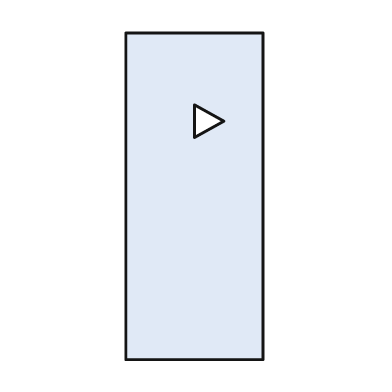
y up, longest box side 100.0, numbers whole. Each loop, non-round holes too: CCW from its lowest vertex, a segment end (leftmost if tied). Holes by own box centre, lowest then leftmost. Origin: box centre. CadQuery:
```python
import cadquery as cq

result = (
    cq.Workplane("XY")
    .moveTo(-21.0, -50.0)
    .lineTo(21.0, -50.0)
    .lineTo(21.0, 50.0)
    .lineTo(-21.0, 50.0)
    .close()
    .moveTo(0.0, 18.0)
    .lineTo(9.0, 23.0)
    .lineTo(0.0, 28.0)
    .close()
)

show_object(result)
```